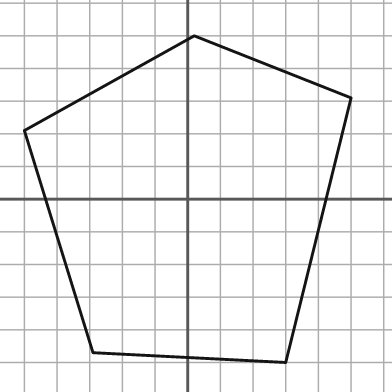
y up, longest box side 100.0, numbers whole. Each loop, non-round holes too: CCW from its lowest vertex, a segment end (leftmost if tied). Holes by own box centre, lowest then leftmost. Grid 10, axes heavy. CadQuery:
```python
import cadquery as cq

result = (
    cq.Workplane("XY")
    .moveTo(30.0, -50.0)
    .lineTo(50.0, 31.0)
    .lineTo(2.0, 50.0)
    .lineTo(-50.0, 21.0)
    .lineTo(-29.0, -47.0)
    .close()
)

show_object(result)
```